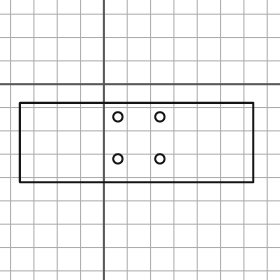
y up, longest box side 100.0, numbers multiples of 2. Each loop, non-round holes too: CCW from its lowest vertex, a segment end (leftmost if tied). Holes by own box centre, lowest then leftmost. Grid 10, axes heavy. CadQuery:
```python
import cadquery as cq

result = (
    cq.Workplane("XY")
    .moveTo(-36.0, -42.0)
    .lineTo(64.0, -42.0)
    .lineTo(64.0, -8.0)
    .lineTo(-36.0, -8.0)
    .close()
    .moveTo(6.0, -32.0)
    .circle(2.0)
    .moveTo(24.0, -32.0)
    .circle(2.0)
    .moveTo(6.0, -14.0)
    .circle(2.0)
    .moveTo(24.0, -14.0)
    .circle(2.0)
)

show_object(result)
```